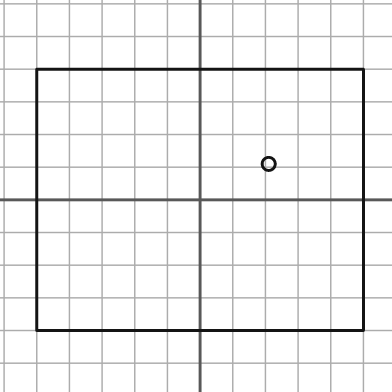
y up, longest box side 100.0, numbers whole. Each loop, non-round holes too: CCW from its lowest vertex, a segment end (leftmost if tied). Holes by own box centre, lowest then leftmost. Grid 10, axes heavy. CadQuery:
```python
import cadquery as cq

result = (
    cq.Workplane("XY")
    .moveTo(-50.0, -40.0)
    .lineTo(50.0, -40.0)
    .lineTo(50.0, 40.0)
    .lineTo(-50.0, 40.0)
    .close()
    .moveTo(21.0, 11.0)
    .circle(2.0)
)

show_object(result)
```